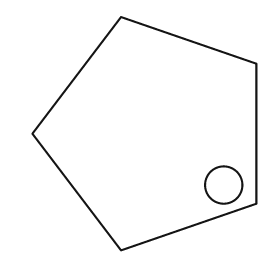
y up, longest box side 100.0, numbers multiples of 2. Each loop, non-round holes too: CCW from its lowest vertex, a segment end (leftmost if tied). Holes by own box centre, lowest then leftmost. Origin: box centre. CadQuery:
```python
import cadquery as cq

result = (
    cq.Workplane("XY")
    .moveTo(-10.0, -50.0)
    .lineTo(48.0, -30.0)
    .lineTo(48.0, 30.0)
    .lineTo(-10.0, 50.0)
    .lineTo(-48.0, 0.0)
    .close()
    .moveTo(34.0, -22.0)
    .circle(8.0)
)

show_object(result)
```